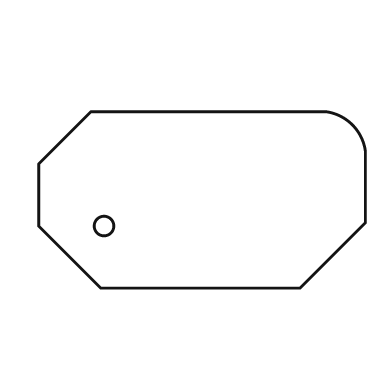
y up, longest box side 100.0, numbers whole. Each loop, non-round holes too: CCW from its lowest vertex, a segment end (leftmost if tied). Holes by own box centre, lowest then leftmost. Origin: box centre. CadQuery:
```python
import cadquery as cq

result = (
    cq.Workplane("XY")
    .moveTo(-31.0, -27.0)
    .lineTo(30.0, -27.0)
    .lineTo(50.0, -7.0)
    .lineTo(50.0, 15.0)
    .threePointArc((46.0, 23.0), (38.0, 27.0))
    .lineTo(-34.0, 27.0)
    .lineTo(-50.0, 11.0)
    .lineTo(-50.0, -8.0)
    .close()
    .moveTo(-30.0, -8.0)
    .circle(3.0)
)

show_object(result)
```